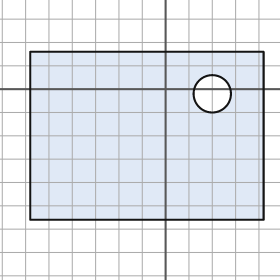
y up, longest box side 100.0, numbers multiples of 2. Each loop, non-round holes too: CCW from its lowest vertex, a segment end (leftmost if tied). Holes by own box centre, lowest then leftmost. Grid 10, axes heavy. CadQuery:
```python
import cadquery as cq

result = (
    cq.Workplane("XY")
    .moveTo(-58.0, -56.0)
    .lineTo(42.0, -56.0)
    .lineTo(42.0, 16.0)
    .lineTo(-58.0, 16.0)
    .close()
    .moveTo(20.0, -2.0)
    .circle(8.0)
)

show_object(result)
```